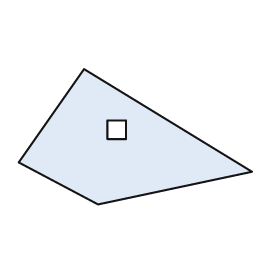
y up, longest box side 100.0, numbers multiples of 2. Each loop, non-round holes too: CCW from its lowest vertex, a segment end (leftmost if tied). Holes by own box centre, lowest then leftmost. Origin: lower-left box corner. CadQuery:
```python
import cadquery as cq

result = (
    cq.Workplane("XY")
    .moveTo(34.0, 0.0)
    .lineTo(100.0, 14.0)
    .lineTo(28.0, 58.0)
    .lineTo(0.0, 18.0)
    .close()
    .moveTo(38.0, 28.0)
    .lineTo(46.0, 28.0)
    .lineTo(46.0, 36.0)
    .lineTo(38.0, 36.0)
    .close()
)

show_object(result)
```